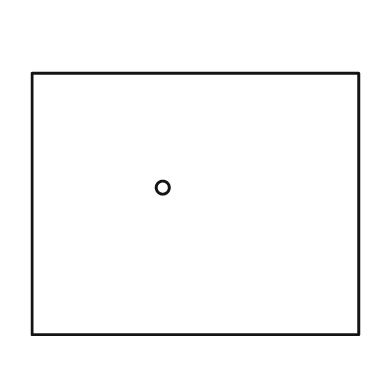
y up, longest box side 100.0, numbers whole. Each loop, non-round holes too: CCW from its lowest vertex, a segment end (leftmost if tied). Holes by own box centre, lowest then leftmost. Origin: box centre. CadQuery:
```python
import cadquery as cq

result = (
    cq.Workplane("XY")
    .moveTo(-50.0, -40.0)
    .lineTo(50.0, -40.0)
    .lineTo(50.0, 40.0)
    .lineTo(-50.0, 40.0)
    .close()
    .moveTo(-10.0, 5.0)
    .circle(2.0)
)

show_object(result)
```